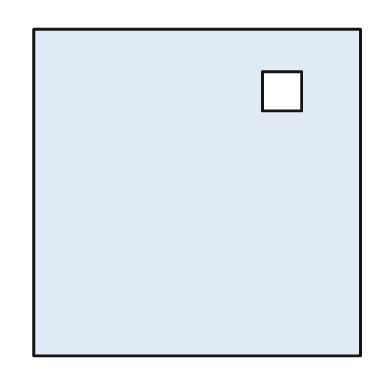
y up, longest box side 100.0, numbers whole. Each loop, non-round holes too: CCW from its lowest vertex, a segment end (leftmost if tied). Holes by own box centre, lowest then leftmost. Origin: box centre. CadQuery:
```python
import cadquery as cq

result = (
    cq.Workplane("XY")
    .moveTo(-50.0, -50.0)
    .lineTo(50.0, -50.0)
    .lineTo(50.0, 50.0)
    .lineTo(-50.0, 50.0)
    .close()
    .moveTo(20.0, 25.0)
    .lineTo(32.0, 25.0)
    .lineTo(32.0, 37.0)
    .lineTo(20.0, 37.0)
    .close()
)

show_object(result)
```